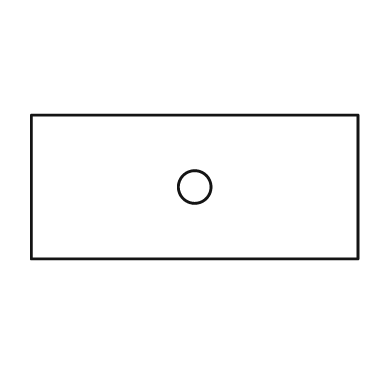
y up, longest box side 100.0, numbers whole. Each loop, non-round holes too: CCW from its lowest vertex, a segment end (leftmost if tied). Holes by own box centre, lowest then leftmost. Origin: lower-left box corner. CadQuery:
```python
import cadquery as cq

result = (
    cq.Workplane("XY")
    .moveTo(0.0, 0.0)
    .lineTo(100.0, 0.0)
    .lineTo(100.0, 44.0)
    .lineTo(0.0, 44.0)
    .close()
    .moveTo(50.0, 22.0)
    .circle(5.0)
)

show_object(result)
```